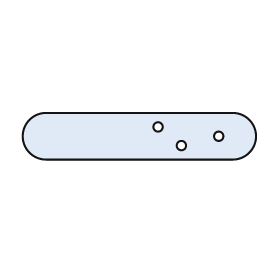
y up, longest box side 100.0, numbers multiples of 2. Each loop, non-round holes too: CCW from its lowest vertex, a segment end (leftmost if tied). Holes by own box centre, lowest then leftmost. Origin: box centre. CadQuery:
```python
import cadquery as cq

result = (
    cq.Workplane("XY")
    .moveTo(-40.0, -10.0)
    .lineTo(40.0, -10.0)
    .threePointArc((50.0, 0.0), (40.0, 10.0))
    .lineTo(-40.0, 10.0)
    .threePointArc((-50.0, 0.0), (-40.0, -10.0))
    .close()
    .moveTo(18.0, -4.0)
    .circle(2.0)
    .moveTo(34.0, 0.0)
    .circle(2.0)
    .moveTo(8.0, 4.0)
    .circle(2.0)
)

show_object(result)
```